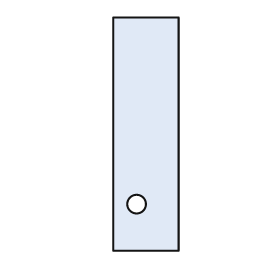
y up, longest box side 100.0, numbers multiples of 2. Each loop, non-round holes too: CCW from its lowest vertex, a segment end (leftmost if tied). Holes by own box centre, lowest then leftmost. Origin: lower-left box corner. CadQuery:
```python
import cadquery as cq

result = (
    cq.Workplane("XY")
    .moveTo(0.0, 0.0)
    .lineTo(28.0, 0.0)
    .lineTo(28.0, 100.0)
    .lineTo(0.0, 100.0)
    .close()
    .moveTo(10.0, 20.0)
    .circle(4.0)
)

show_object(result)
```